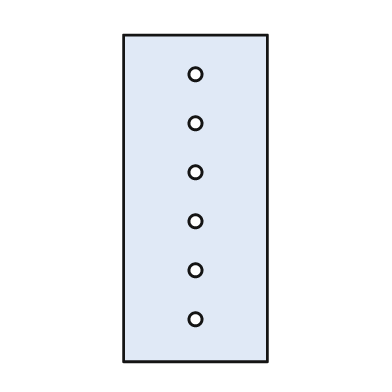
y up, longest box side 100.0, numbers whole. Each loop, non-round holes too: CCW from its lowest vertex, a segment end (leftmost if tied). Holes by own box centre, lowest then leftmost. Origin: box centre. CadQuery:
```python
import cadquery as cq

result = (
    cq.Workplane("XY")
    .moveTo(-22.0, -50.0)
    .lineTo(22.0, -50.0)
    .lineTo(22.0, 50.0)
    .lineTo(-22.0, 50.0)
    .close()
    .moveTo(0.0, -37.0)
    .circle(2.0)
    .moveTo(0.0, -22.0)
    .circle(2.0)
    .moveTo(0.0, -7.0)
    .circle(2.0)
    .moveTo(0.0, 8.0)
    .circle(2.0)
    .moveTo(0.0, 23.0)
    .circle(2.0)
    .moveTo(0.0, 38.0)
    .circle(2.0)
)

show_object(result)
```